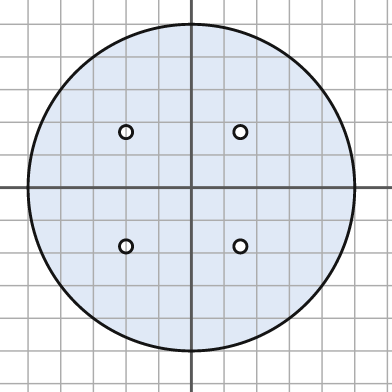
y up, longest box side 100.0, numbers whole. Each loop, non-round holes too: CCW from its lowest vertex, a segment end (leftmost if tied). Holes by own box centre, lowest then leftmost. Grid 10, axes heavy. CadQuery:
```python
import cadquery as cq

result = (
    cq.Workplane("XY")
    .moveTo(0.0, 0.0)
    .circle(50.0)
    .moveTo(-20.0, -18.0)
    .circle(2.0)
    .moveTo(15.0, -18.0)
    .circle(2.0)
    .moveTo(-20.0, 17.0)
    .circle(2.0)
    .moveTo(15.0, 17.0)
    .circle(2.0)
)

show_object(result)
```